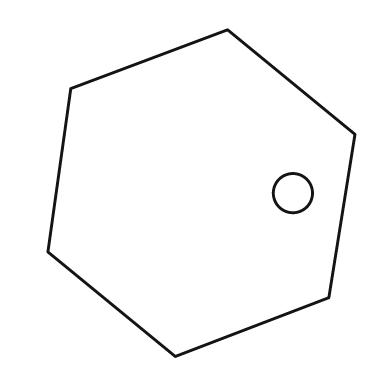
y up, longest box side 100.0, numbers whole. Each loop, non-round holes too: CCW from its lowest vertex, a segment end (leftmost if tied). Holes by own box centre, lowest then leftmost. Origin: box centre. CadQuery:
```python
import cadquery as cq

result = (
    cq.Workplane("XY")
    .moveTo(-8.0, -50.0)
    .lineTo(39.0, -32.0)
    .lineTo(47.0, 18.0)
    .lineTo(8.0, 50.0)
    .lineTo(-40.0, 32.0)
    .lineTo(-47.0, -18.0)
    .close()
    .moveTo(28.0, 0.0)
    .circle(6.0)
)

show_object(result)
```